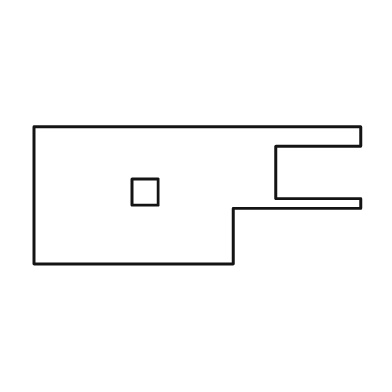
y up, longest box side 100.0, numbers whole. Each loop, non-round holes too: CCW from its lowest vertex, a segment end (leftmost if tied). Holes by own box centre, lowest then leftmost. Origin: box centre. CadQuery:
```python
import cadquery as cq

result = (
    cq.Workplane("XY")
    .moveTo(-50.0, -21.0)
    .lineTo(11.0, -21.0)
    .lineTo(11.0, -4.0)
    .lineTo(50.0, -4.0)
    .lineTo(50.0, -1.0)
    .lineTo(24.0, -1.0)
    .lineTo(24.0, 15.0)
    .lineTo(50.0, 15.0)
    .lineTo(50.0, 21.0)
    .lineTo(-50.0, 21.0)
    .close()
    .moveTo(-20.0, -3.0)
    .lineTo(-12.0, -3.0)
    .lineTo(-12.0, 5.0)
    .lineTo(-20.0, 5.0)
    .close()
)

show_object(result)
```